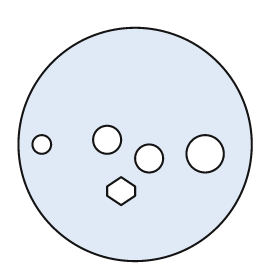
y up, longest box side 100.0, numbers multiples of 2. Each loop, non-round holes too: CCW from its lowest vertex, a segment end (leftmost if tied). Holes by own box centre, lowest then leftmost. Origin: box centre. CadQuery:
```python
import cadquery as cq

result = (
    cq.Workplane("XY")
    .moveTo(0.0, 0.0)
    .circle(50.0)
    .moveTo(-6.0, -26.0)
    .lineTo(0.0, -22.0)
    .lineTo(0.0, -18.0)
    .lineTo(-6.0, -14.0)
    .lineTo(-12.0, -18.0)
    .lineTo(-12.0, -22.0)
    .close()
    .moveTo(6.0, -6.0)
    .circle(6.0)
    .moveTo(30.0, -4.0)
    .circle(8.0)
    .moveTo(-40.0, 0.0)
    .circle(4.0)
    .moveTo(-12.0, 2.0)
    .circle(6.0)
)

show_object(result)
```